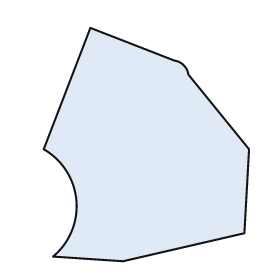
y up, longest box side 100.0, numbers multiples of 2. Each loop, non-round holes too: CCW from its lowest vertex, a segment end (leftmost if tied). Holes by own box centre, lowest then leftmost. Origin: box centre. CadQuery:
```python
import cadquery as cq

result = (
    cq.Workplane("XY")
    .moveTo(-10.0, -50.0)
    .lineTo(42.0, -38.0)
    .lineTo(44.0, -2.0)
    .lineTo(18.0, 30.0)
    .threePointArc((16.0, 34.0), (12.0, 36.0))
    .lineTo(-24.0, 50.0)
    .lineTo(-44.0, -2.0)
    .threePointArc((-30.0, -24.0), (-40.0, -48.0))
    .close()
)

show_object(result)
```